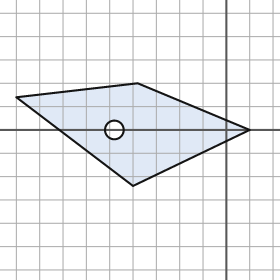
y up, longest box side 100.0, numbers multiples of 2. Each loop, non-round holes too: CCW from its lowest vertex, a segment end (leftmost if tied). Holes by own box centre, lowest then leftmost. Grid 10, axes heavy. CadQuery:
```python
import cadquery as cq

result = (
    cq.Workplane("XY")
    .moveTo(-40.0, -24.0)
    .lineTo(10.0, 0.0)
    .lineTo(-38.0, 20.0)
    .lineTo(-90.0, 14.0)
    .close()
    .moveTo(-48.0, 0.0)
    .circle(4.0)
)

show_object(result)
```